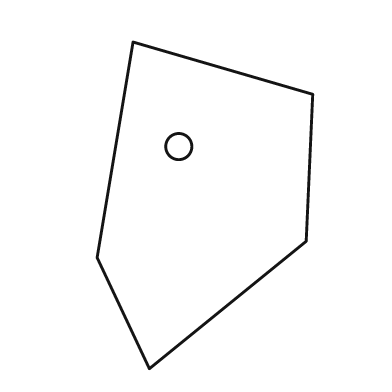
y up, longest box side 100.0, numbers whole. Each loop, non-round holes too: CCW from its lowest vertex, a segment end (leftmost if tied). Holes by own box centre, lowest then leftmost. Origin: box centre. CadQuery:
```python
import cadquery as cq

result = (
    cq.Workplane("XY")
    .moveTo(-17.0, -50.0)
    .lineTo(31.0, -11.0)
    .lineTo(33.0, 34.0)
    .lineTo(-22.0, 50.0)
    .lineTo(-33.0, -16.0)
    .close()
    .moveTo(-8.0, 18.0)
    .circle(4.0)
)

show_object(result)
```